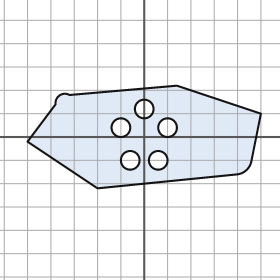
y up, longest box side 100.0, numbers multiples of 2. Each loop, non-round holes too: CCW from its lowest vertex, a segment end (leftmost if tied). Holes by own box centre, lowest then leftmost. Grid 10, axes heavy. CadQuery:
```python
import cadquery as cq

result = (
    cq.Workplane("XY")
    .moveTo(-20.0, -22.0)
    .lineTo(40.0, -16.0)
    .threePointArc((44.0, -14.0), (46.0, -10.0))
    .lineTo(50.0, 10.0)
    .lineTo(14.0, 22.0)
    .lineTo(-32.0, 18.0)
    .threePointArc((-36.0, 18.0), (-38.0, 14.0))
    .lineTo(-50.0, -2.0)
    .close()
    .moveTo(-6.0, -10.0)
    .circle(4.0)
    .moveTo(6.0, -10.0)
    .circle(4.0)
    .moveTo(-10.0, 4.0)
    .circle(4.0)
    .moveTo(10.0, 4.0)
    .circle(4.0)
    .moveTo(0.0, 12.0)
    .circle(4.0)
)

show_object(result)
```